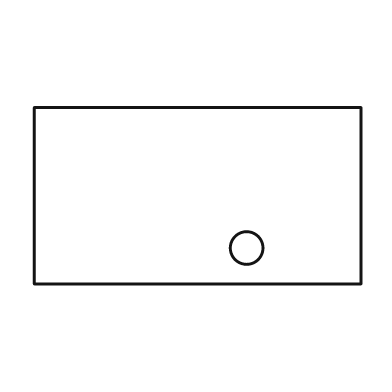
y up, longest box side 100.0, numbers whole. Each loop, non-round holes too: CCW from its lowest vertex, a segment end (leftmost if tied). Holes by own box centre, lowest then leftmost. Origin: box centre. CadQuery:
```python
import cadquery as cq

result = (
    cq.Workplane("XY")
    .moveTo(-50.0, -27.0)
    .lineTo(50.0, -27.0)
    .lineTo(50.0, 27.0)
    .lineTo(-50.0, 27.0)
    .close()
    .moveTo(15.0, -16.0)
    .circle(5.0)
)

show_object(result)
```